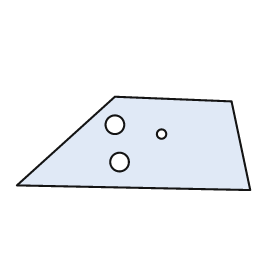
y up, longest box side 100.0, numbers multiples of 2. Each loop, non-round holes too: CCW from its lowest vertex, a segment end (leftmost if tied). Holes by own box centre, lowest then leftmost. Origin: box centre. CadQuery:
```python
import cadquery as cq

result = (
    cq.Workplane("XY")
    .moveTo(50.0, -20.0)
    .lineTo(42.0, 18.0)
    .lineTo(-8.0, 20.0)
    .lineTo(-50.0, -18.0)
    .close()
    .moveTo(-6.0, -8.0)
    .circle(4.0)
    .moveTo(12.0, 4.0)
    .circle(2.0)
    .moveTo(-8.0, 8.0)
    .circle(4.0)
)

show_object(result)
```